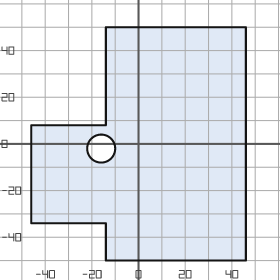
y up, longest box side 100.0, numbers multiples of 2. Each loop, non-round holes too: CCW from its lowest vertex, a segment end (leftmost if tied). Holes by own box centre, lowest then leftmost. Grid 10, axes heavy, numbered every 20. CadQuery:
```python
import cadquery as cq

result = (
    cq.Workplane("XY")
    .moveTo(-14.0, -50.0)
    .lineTo(46.0, -50.0)
    .lineTo(46.0, 50.0)
    .lineTo(-14.0, 50.0)
    .lineTo(-14.0, 8.0)
    .lineTo(-46.0, 8.0)
    .lineTo(-46.0, -34.0)
    .lineTo(-14.0, -34.0)
    .close()
    .moveTo(-16.0, -2.0)
    .circle(6.0)
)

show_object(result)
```